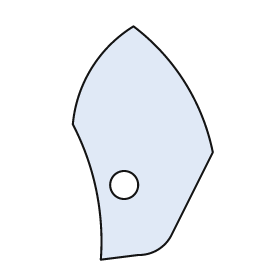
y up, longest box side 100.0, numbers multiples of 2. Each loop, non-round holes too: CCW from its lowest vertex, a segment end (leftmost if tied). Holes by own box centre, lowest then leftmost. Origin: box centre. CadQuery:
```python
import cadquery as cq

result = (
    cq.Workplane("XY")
    .moveTo(-18.0, -50.0)
    .lineTo(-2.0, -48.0)
    .threePointArc((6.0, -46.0), (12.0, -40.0))
    .lineTo(30.0, -4.0)
    .threePointArc((18.0, 26.0), (-4.0, 50.0))
    .threePointArc((-22.0, 32.0), (-30.0, 8.0))
    .threePointArc((-20.0, -20.0), (-18.0, -50.0))
    .close()
    .moveTo(-8.0, -18.0)
    .circle(6.0)
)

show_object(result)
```